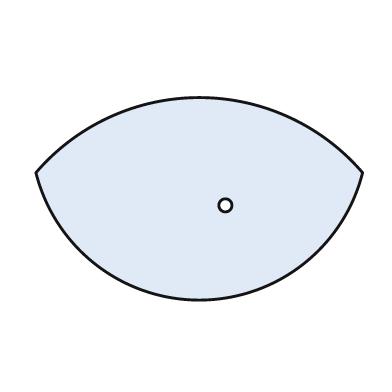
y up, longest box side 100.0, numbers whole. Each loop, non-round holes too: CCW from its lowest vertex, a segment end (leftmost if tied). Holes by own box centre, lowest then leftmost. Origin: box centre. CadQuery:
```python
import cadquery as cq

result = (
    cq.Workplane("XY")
    .moveTo(-50.0, 8.0)
    .threePointArc((0.0, -31.0), (50.0, 8.0))
    .threePointArc((0.0, 31.0), (-50.0, 8.0))
    .close()
    .moveTo(8.0, -2.0)
    .circle(2.0)
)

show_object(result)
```